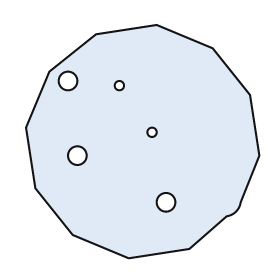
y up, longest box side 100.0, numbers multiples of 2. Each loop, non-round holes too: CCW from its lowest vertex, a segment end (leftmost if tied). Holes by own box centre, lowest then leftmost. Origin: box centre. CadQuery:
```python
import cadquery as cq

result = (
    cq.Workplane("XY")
    .moveTo(-6.0, -50.0)
    .lineTo(20.0, -46.0)
    .lineTo(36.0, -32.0)
    .threePointArc((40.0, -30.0), (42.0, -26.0))
    .lineTo(50.0, -6.0)
    .lineTo(46.0, 20.0)
    .lineTo(30.0, 40.0)
    .lineTo(6.0, 50.0)
    .lineTo(-20.0, 46.0)
    .lineTo(-40.0, 30.0)
    .lineTo(-50.0, 6.0)
    .lineTo(-46.0, -20.0)
    .lineTo(-30.0, -40.0)
    .close()
    .moveTo(10.0, -26.0)
    .circle(4.0)
    .moveTo(-28.0, -6.0)
    .circle(4.0)
    .moveTo(4.0, 4.0)
    .circle(2.0)
    .moveTo(-10.0, 24.0)
    .circle(2.0)
    .moveTo(-32.0, 26.0)
    .circle(4.0)
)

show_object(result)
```